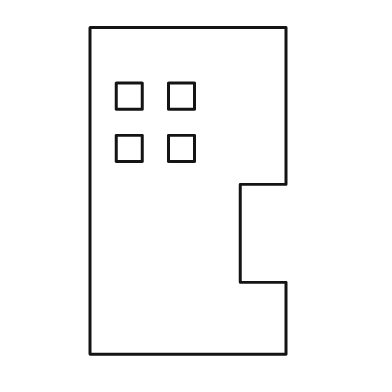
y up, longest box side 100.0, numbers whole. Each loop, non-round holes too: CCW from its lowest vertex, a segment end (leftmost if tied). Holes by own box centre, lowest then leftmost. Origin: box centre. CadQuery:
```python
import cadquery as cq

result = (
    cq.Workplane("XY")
    .moveTo(-30.0, -50.0)
    .lineTo(30.0, -50.0)
    .lineTo(30.0, -28.0)
    .lineTo(16.0, -28.0)
    .lineTo(16.0, 2.0)
    .lineTo(30.0, 2.0)
    .lineTo(30.0, 50.0)
    .lineTo(-30.0, 50.0)
    .close()
    .moveTo(-22.0, 9.0)
    .lineTo(-14.0, 9.0)
    .lineTo(-14.0, 17.0)
    .lineTo(-22.0, 17.0)
    .close()
    .moveTo(-6.0, 9.0)
    .lineTo(2.0, 9.0)
    .lineTo(2.0, 17.0)
    .lineTo(-6.0, 17.0)
    .close()
    .moveTo(-22.0, 25.0)
    .lineTo(-14.0, 25.0)
    .lineTo(-14.0, 33.0)
    .lineTo(-22.0, 33.0)
    .close()
    .moveTo(-6.0, 25.0)
    .lineTo(2.0, 25.0)
    .lineTo(2.0, 33.0)
    .lineTo(-6.0, 33.0)
    .close()
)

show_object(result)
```